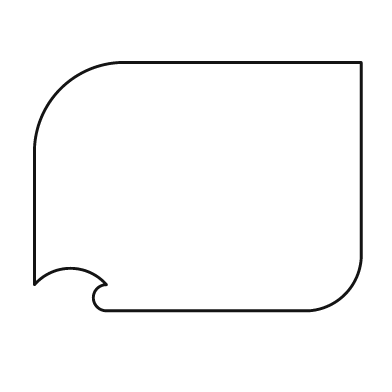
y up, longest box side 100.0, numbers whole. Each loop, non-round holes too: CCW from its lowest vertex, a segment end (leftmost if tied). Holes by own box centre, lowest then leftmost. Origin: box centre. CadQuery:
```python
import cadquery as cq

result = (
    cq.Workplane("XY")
    .moveTo(-28.0, -38.0)
    .lineTo(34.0, -38.0)
    .threePointArc((45.0, -33.0), (50.0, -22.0))
    .lineTo(50.0, 38.0)
    .lineTo(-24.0, 38.0)
    .threePointArc((-42.0, 30.0), (-50.0, 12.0))
    .lineTo(-50.0, -30.0)
    .threePointArc((-39.0, -25.0), (-28.0, -30.0))
    .threePointArc((-32.0, -34.0), (-28.0, -38.0))
    .close()
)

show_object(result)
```